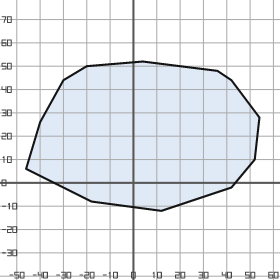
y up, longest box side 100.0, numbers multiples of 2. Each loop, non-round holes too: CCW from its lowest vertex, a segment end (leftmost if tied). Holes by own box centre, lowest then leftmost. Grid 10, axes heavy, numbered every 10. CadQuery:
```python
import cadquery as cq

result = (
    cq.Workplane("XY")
    .moveTo(12.0, -12.0)
    .lineTo(42.0, -2.0)
    .lineTo(52.0, 10.0)
    .lineTo(54.0, 28.0)
    .lineTo(42.0, 44.0)
    .lineTo(36.0, 48.0)
    .lineTo(4.0, 52.0)
    .lineTo(-20.0, 50.0)
    .lineTo(-30.0, 44.0)
    .lineTo(-40.0, 26.0)
    .lineTo(-46.0, 6.0)
    .lineTo(-18.0, -8.0)
    .close()
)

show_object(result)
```